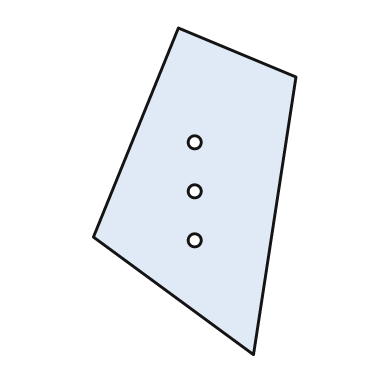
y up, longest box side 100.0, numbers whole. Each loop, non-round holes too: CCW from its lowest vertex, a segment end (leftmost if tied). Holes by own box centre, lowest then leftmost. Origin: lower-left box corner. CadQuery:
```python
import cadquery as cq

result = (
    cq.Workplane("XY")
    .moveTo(49.0, 0.0)
    .lineTo(62.0, 85.0)
    .lineTo(26.0, 100.0)
    .lineTo(0.0, 36.0)
    .close()
    .moveTo(31.0, 35.0)
    .circle(2.0)
    .moveTo(31.0, 50.0)
    .circle(2.0)
    .moveTo(31.0, 65.0)
    .circle(2.0)
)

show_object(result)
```